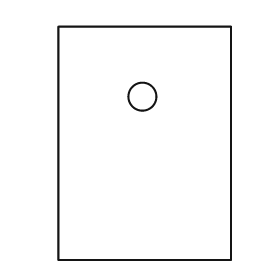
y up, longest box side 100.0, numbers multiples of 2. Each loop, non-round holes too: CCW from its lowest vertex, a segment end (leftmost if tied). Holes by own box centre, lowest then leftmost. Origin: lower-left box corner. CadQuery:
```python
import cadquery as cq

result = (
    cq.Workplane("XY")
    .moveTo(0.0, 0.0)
    .lineTo(74.0, 0.0)
    .lineTo(74.0, 100.0)
    .lineTo(0.0, 100.0)
    .close()
    .moveTo(36.0, 70.0)
    .circle(6.0)
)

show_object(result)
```